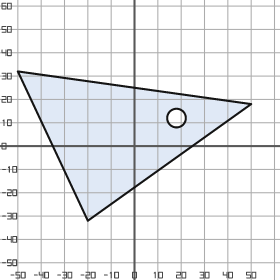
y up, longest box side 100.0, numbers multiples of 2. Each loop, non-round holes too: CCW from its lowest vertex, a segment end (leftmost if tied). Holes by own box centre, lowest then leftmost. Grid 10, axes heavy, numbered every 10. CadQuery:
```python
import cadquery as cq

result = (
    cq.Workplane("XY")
    .moveTo(-20.0, -32.0)
    .lineTo(50.0, 18.0)
    .lineTo(-50.0, 32.0)
    .close()
    .moveTo(18.0, 12.0)
    .circle(4.0)
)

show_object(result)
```